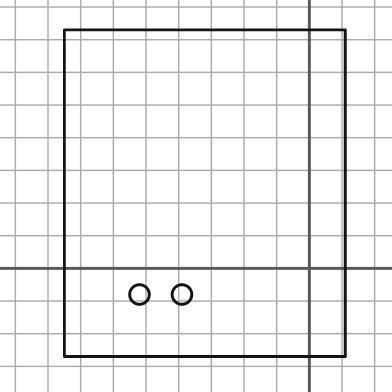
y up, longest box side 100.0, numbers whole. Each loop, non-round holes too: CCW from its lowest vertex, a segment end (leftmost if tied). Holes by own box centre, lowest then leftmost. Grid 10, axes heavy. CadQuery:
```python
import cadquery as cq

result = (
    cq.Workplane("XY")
    .moveTo(-75.0, -27.0)
    .lineTo(11.0, -27.0)
    .lineTo(11.0, 73.0)
    .lineTo(-75.0, 73.0)
    .close()
    .moveTo(-52.0, -8.0)
    .circle(3.0)
    .moveTo(-39.0, -8.0)
    .circle(3.0)
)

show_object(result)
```